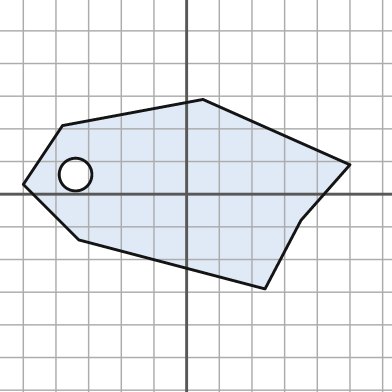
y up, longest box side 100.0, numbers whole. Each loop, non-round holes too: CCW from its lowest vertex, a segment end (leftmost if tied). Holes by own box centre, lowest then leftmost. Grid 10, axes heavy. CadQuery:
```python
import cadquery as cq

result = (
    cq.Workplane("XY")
    .moveTo(24.0, -29.0)
    .lineTo(35.0, -8.0)
    .lineTo(50.0, 9.0)
    .lineTo(5.0, 29.0)
    .lineTo(-38.0, 21.0)
    .lineTo(-50.0, 3.0)
    .lineTo(-33.0, -14.0)
    .close()
    .moveTo(-34.0, 6.0)
    .circle(5.0)
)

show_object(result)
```